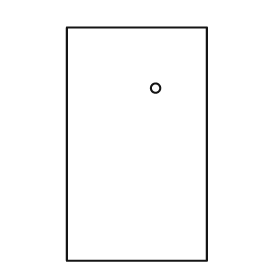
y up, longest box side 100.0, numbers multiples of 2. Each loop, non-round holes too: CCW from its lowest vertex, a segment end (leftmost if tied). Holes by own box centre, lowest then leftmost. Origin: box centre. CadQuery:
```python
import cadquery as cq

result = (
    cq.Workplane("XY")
    .moveTo(-30.0, -50.0)
    .lineTo(30.0, -50.0)
    .lineTo(30.0, 50.0)
    .lineTo(-30.0, 50.0)
    .close()
    .moveTo(8.0, 24.0)
    .circle(2.0)
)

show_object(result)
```